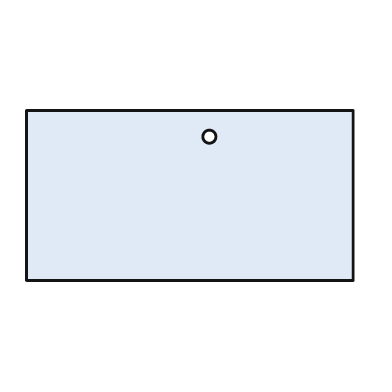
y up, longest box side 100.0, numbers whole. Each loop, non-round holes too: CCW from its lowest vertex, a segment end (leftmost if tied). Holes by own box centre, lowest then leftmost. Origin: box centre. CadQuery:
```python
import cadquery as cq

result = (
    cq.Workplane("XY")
    .moveTo(-50.0, -26.0)
    .lineTo(50.0, -26.0)
    .lineTo(50.0, 26.0)
    .lineTo(-50.0, 26.0)
    .close()
    .moveTo(6.0, 18.0)
    .circle(2.0)
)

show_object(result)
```